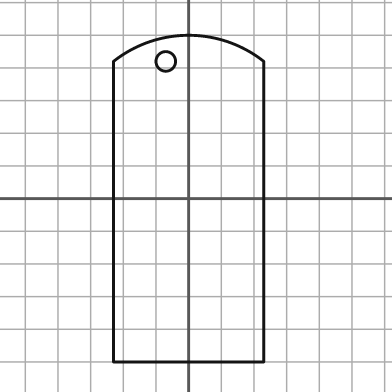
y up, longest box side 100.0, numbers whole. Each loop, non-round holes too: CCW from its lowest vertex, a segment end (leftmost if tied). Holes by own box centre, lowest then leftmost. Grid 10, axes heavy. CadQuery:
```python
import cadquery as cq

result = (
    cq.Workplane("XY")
    .moveTo(-23.0, -50.0)
    .lineTo(23.0, -50.0)
    .lineTo(23.0, 42.0)
    .threePointArc((0.0, 50.0), (-23.0, 42.0))
    .close()
    .moveTo(-7.0, 42.0)
    .circle(3.0)
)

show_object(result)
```